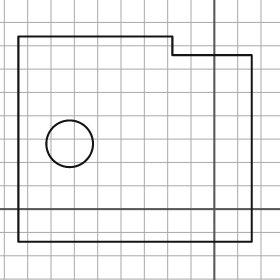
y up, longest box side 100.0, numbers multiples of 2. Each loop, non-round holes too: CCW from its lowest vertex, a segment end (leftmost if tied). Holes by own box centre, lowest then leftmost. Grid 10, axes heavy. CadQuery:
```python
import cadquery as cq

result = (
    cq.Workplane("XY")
    .moveTo(-84.0, -14.0)
    .lineTo(16.0, -14.0)
    .lineTo(16.0, 66.0)
    .lineTo(-18.0, 66.0)
    .lineTo(-18.0, 74.0)
    .lineTo(-84.0, 74.0)
    .close()
    .moveTo(-62.0, 28.0)
    .circle(10.0)
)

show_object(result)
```